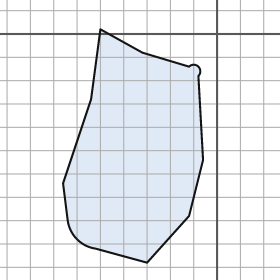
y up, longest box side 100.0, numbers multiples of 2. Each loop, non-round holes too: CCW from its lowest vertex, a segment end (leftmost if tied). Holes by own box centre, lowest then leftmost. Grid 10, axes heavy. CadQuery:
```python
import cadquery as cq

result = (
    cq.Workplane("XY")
    .moveTo(-30.0, -98.0)
    .lineTo(-12.0, -78.0)
    .lineTo(-6.0, -54.0)
    .lineTo(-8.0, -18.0)
    .threePointArc((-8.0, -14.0), (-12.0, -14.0))
    .lineTo(-32.0, -8.0)
    .lineTo(-50.0, 2.0)
    .lineTo(-54.0, -28.0)
    .lineTo(-66.0, -64.0)
    .lineTo(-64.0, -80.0)
    .threePointArc((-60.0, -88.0), (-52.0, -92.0))
    .close()
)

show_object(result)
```